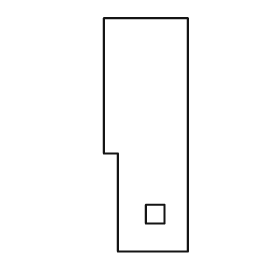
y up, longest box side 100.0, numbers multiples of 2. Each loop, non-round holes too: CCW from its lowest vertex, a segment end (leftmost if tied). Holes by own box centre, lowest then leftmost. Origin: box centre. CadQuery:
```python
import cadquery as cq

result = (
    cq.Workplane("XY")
    .moveTo(-12.0, -50.0)
    .lineTo(18.0, -50.0)
    .lineTo(18.0, 50.0)
    .lineTo(-18.0, 50.0)
    .lineTo(-18.0, -8.0)
    .lineTo(-12.0, -8.0)
    .close()
    .moveTo(0.0, -38.0)
    .lineTo(8.0, -38.0)
    .lineTo(8.0, -30.0)
    .lineTo(0.0, -30.0)
    .close()
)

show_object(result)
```